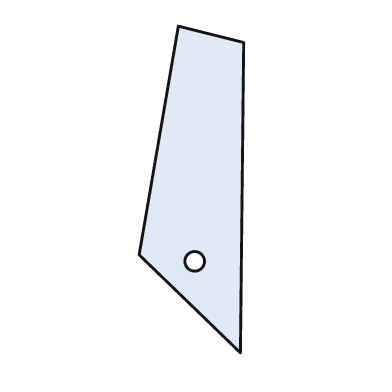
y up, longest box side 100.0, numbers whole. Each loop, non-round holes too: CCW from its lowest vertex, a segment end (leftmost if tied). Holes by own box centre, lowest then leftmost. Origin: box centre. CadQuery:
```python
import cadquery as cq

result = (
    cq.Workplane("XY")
    .moveTo(15.0, -50.0)
    .lineTo(16.0, 45.0)
    .lineTo(-4.0, 50.0)
    .lineTo(-16.0, -20.0)
    .close()
    .moveTo(1.0, -22.0)
    .circle(3.0)
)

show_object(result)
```